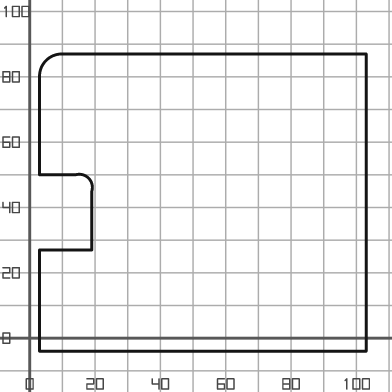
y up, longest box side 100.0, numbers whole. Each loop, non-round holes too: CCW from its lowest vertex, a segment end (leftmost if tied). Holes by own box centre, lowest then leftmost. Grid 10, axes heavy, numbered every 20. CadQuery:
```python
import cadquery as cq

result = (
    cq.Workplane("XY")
    .moveTo(3.0, -4.0)
    .lineTo(103.0, -4.0)
    .lineTo(103.0, 87.0)
    .lineTo(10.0, 87.0)
    .threePointArc((5.0, 85.0), (3.0, 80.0))
    .lineTo(3.0, 50.0)
    .lineTo(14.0, 50.0)
    .threePointArc((18.0, 49.0), (19.0, 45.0))
    .lineTo(19.0, 27.0)
    .lineTo(3.0, 27.0)
    .close()
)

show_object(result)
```